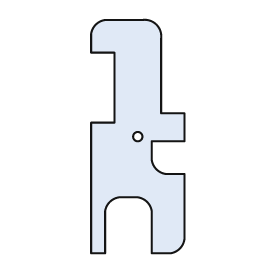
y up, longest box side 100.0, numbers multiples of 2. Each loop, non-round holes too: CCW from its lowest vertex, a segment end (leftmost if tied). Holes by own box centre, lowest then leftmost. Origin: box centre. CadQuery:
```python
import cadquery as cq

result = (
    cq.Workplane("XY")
    .moveTo(-20.0, -50.0)
    .lineTo(-14.0, -50.0)
    .lineTo(-14.0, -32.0)
    .threePointArc((-12.0, -28.0), (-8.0, -26.0))
    .lineTo(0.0, -26.0)
    .threePointArc((4.0, -28.0), (6.0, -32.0))
    .lineTo(6.0, -50.0)
    .lineTo(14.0, -50.0)
    .threePointArc((18.0, -48.0), (20.0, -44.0))
    .lineTo(20.0, -16.0)
    .lineTo(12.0, -16.0)
    .threePointArc((8.0, -14.0), (6.0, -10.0))
    .lineTo(6.0, -2.0)
    .lineTo(20.0, -2.0)
    .lineTo(20.0, 10.0)
    .lineTo(10.0, 10.0)
    .lineTo(10.0, 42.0)
    .threePointArc((8.0, 48.0), (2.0, 50.0))
    .lineTo(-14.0, 50.0)
    .threePointArc((-18.0, 48.0), (-20.0, 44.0))
    .lineTo(-20.0, 36.0)
    .lineTo(-10.0, 36.0)
    .lineTo(-10.0, 6.0)
    .lineTo(-20.0, 6.0)
    .close()
    .moveTo(0.0, 0.0)
    .circle(2.0)
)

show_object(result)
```